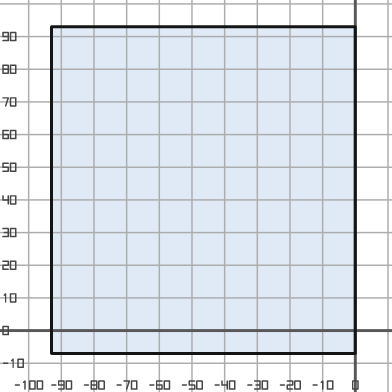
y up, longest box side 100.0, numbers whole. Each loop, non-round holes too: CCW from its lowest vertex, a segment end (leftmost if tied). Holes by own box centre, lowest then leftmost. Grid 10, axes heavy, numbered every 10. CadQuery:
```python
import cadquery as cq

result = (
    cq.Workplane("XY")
    .moveTo(-93.0, -7.0)
    .lineTo(0.0, -7.0)
    .lineTo(0.0, 93.0)
    .lineTo(-93.0, 93.0)
    .close()
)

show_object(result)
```